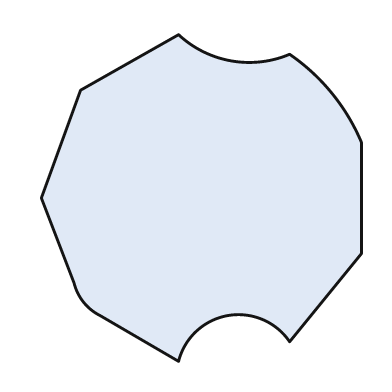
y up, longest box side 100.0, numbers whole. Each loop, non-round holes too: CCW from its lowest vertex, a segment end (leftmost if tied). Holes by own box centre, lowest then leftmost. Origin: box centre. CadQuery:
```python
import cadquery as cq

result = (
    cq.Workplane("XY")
    .moveTo(-7.0, -50.0)
    .threePointArc((8.0, -36.0), (27.0, -44.0))
    .lineTo(49.0, -17.0)
    .lineTo(49.0, 17.0)
    .threePointArc((40.0, 32.0), (27.0, 44.0))
    .threePointArc((9.0, 42.0), (-7.0, 50.0))
    .lineTo(-37.0, 33.0)
    .lineTo(-49.0, 0.0)
    .lineTo(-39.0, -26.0)
    .threePointArc((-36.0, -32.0), (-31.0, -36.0))
    .close()
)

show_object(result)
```